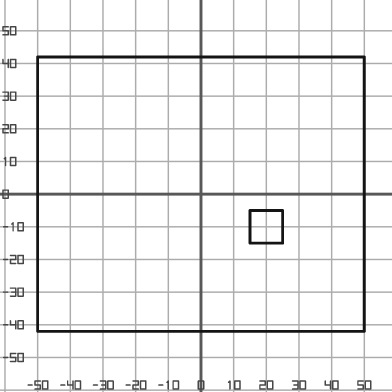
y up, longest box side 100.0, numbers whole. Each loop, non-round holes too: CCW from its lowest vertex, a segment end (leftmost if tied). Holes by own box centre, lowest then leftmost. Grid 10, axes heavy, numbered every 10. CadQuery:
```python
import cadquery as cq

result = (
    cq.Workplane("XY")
    .moveTo(-50.0, -42.0)
    .lineTo(50.0, -42.0)
    .lineTo(50.0, 42.0)
    .lineTo(-50.0, 42.0)
    .close()
    .moveTo(15.0, -15.0)
    .lineTo(25.0, -15.0)
    .lineTo(25.0, -5.0)
    .lineTo(15.0, -5.0)
    .close()
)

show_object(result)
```